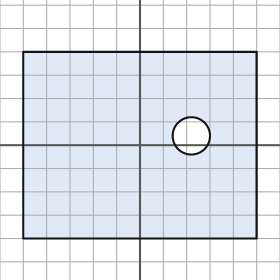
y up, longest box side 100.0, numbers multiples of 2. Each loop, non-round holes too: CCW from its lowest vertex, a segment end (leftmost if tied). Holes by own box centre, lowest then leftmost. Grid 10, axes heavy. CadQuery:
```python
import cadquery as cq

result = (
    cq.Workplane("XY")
    .moveTo(-50.0, -40.0)
    .lineTo(50.0, -40.0)
    .lineTo(50.0, 40.0)
    .lineTo(-50.0, 40.0)
    .close()
    .moveTo(22.0, 4.0)
    .circle(8.0)
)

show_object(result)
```